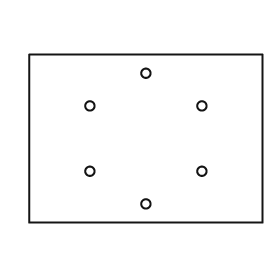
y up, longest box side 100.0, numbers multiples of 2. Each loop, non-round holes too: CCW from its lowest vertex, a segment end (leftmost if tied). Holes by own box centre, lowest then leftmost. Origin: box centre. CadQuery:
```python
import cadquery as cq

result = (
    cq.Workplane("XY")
    .moveTo(-50.0, -36.0)
    .lineTo(50.0, -36.0)
    .lineTo(50.0, 36.0)
    .lineTo(-50.0, 36.0)
    .close()
    .moveTo(0.0, -28.0)
    .circle(2.0)
    .moveTo(-24.0, -14.0)
    .circle(2.0)
    .moveTo(24.0, -14.0)
    .circle(2.0)
    .moveTo(-24.0, 14.0)
    .circle(2.0)
    .moveTo(24.0, 14.0)
    .circle(2.0)
    .moveTo(0.0, 28.0)
    .circle(2.0)
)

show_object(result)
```